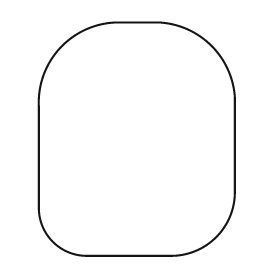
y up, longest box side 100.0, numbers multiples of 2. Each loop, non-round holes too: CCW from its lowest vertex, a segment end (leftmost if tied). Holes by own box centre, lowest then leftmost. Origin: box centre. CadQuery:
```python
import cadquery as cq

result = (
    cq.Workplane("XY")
    .moveTo(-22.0, -50.0)
    .lineTo(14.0, -50.0)
    .threePointArc((34.0, -42.0), (42.0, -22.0))
    .lineTo(42.0, 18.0)
    .threePointArc((32.0, 40.0), (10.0, 50.0))
    .lineTo(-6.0, 50.0)
    .threePointArc((-32.0, 40.0), (-42.0, 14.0))
    .lineTo(-42.0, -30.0)
    .threePointArc((-36.0, -44.0), (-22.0, -50.0))
    .close()
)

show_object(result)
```